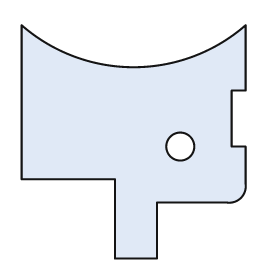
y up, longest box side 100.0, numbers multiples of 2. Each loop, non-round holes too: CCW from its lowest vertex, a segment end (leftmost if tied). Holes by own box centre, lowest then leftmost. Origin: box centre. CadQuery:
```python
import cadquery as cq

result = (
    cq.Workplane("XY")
    .moveTo(-8.0, -50.0)
    .lineTo(10.0, -50.0)
    .lineTo(10.0, -26.0)
    .lineTo(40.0, -26.0)
    .threePointArc((46.0, -24.0), (48.0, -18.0))
    .lineTo(48.0, -2.0)
    .lineTo(42.0, -2.0)
    .lineTo(42.0, 22.0)
    .lineTo(48.0, 22.0)
    .lineTo(48.0, 50.0)
    .threePointArc((0.0, 32.0), (-48.0, 50.0))
    .lineTo(-48.0, -16.0)
    .lineTo(-8.0, -16.0)
    .close()
    .moveTo(20.0, -2.0)
    .circle(6.0)
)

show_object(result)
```